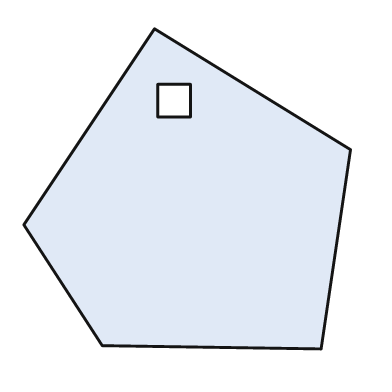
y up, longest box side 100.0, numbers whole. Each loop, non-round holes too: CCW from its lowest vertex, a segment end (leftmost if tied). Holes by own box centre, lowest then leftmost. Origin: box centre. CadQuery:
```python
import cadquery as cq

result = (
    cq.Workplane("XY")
    .moveTo(41.0, -49.0)
    .lineTo(50.0, 12.0)
    .lineTo(-10.0, 49.0)
    .lineTo(-50.0, -11.0)
    .lineTo(-26.0, -48.0)
    .close()
    .moveTo(-9.0, 22.0)
    .lineTo(1.0, 22.0)
    .lineTo(1.0, 32.0)
    .lineTo(-9.0, 32.0)
    .close()
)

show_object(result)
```